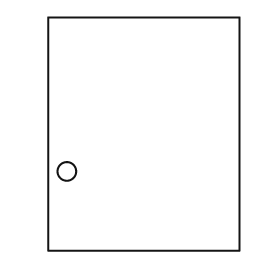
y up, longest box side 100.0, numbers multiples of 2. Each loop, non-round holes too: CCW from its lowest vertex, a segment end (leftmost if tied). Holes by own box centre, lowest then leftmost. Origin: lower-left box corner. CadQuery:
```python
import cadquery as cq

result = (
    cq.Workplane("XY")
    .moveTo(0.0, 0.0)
    .lineTo(82.0, 0.0)
    .lineTo(82.0, 100.0)
    .lineTo(0.0, 100.0)
    .close()
    .moveTo(8.0, 34.0)
    .circle(4.0)
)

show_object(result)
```